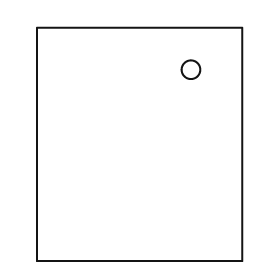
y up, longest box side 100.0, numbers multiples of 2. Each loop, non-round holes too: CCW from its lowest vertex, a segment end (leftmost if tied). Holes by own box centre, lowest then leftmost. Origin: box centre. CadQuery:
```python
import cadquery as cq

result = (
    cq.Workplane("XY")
    .moveTo(-44.0, -50.0)
    .lineTo(44.0, -50.0)
    .lineTo(44.0, 50.0)
    .lineTo(-44.0, 50.0)
    .close()
    .moveTo(22.0, 32.0)
    .circle(4.0)
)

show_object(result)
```